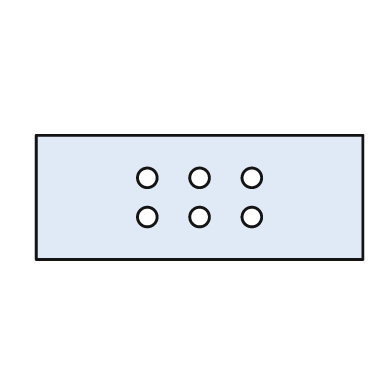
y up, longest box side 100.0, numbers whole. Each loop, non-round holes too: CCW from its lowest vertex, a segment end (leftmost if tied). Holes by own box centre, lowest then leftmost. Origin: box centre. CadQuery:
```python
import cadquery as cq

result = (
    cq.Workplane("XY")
    .moveTo(-50.0, -19.0)
    .lineTo(50.0, -19.0)
    .lineTo(50.0, 19.0)
    .lineTo(-50.0, 19.0)
    .close()
    .moveTo(-16.0, -6.0)
    .circle(3.0)
    .moveTo(0.0, -6.0)
    .circle(3.0)
    .moveTo(16.0, -6.0)
    .circle(3.0)
    .moveTo(-16.0, 6.0)
    .circle(3.0)
    .moveTo(0.0, 6.0)
    .circle(3.0)
    .moveTo(16.0, 6.0)
    .circle(3.0)
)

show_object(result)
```